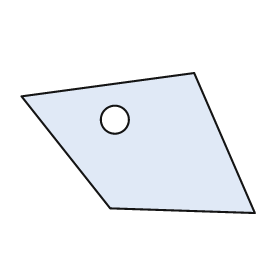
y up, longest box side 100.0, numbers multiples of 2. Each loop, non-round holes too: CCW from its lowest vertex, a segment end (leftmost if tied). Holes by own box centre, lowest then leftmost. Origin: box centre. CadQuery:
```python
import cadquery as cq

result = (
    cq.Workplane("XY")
    .moveTo(50.0, -30.0)
    .lineTo(24.0, 30.0)
    .lineTo(-50.0, 20.0)
    .lineTo(-12.0, -28.0)
    .close()
    .moveTo(-10.0, 10.0)
    .circle(6.0)
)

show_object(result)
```